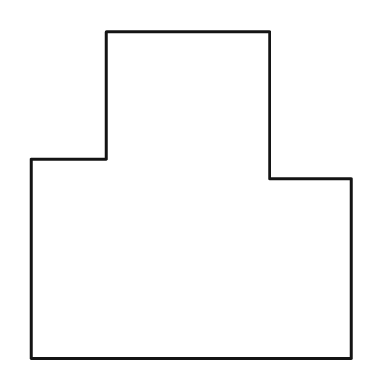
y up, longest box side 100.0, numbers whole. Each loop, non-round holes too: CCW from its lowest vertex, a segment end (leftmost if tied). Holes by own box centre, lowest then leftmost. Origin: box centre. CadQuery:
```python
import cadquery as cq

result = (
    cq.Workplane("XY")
    .moveTo(-49.0, -50.0)
    .lineTo(49.0, -50.0)
    .lineTo(49.0, 5.0)
    .lineTo(24.0, 5.0)
    .lineTo(24.0, 50.0)
    .lineTo(-26.0, 50.0)
    .lineTo(-26.0, 11.0)
    .lineTo(-49.0, 11.0)
    .close()
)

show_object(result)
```